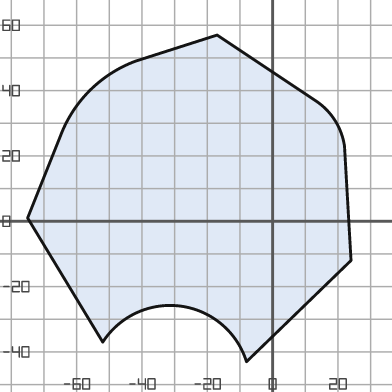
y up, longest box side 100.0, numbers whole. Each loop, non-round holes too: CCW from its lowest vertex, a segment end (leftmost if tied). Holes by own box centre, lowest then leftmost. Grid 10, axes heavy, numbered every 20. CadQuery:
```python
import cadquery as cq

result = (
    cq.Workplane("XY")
    .moveTo(-8.0, -43.0)
    .lineTo(24.0, -12.0)
    .lineTo(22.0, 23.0)
    .threePointArc((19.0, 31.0), (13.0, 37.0))
    .lineTo(-17.0, 57.0)
    .lineTo(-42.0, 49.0)
    .threePointArc((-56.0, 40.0), (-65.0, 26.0))
    .lineTo(-75.0, 1.0)
    .lineTo(-52.0, -37.0)
    .threePointArc((-28.0, -26.0), (-8.0, -43.0))
    .close()
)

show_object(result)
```